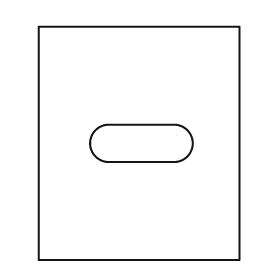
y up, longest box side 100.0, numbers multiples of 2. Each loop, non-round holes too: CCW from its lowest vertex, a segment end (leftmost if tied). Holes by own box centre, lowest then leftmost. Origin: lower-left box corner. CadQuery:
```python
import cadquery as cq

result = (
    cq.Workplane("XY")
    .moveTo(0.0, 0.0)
    .lineTo(86.0, 0.0)
    .lineTo(86.0, 100.0)
    .lineTo(0.0, 100.0)
    .close()
    .moveTo(30.0, 42.0)
    .lineTo(58.0, 42.0)
    .threePointArc((66.0, 50.0), (58.0, 58.0))
    .lineTo(30.0, 58.0)
    .threePointArc((22.0, 50.0), (30.0, 42.0))
    .close()
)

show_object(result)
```